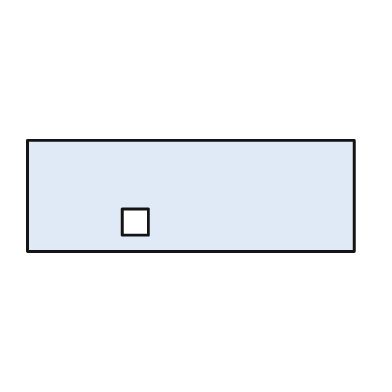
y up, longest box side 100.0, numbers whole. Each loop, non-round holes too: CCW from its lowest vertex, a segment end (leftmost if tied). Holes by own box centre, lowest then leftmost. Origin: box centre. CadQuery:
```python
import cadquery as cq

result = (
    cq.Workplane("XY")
    .moveTo(-50.0, -17.0)
    .lineTo(50.0, -17.0)
    .lineTo(50.0, 17.0)
    .lineTo(-50.0, 17.0)
    .close()
    .moveTo(-21.0, -12.0)
    .lineTo(-13.0, -12.0)
    .lineTo(-13.0, -4.0)
    .lineTo(-21.0, -4.0)
    .close()
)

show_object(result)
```